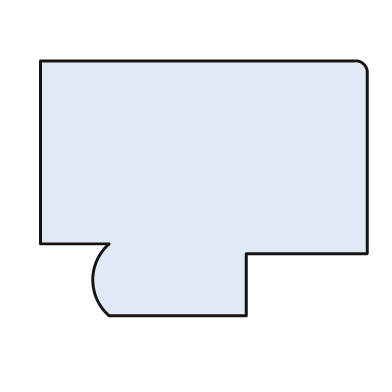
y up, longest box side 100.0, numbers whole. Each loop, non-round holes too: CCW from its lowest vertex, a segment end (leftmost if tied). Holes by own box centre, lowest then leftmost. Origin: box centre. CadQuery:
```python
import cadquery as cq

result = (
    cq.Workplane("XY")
    .moveTo(-29.0, -39.0)
    .lineTo(13.0, -39.0)
    .lineTo(13.0, -20.0)
    .lineTo(50.0, -20.0)
    .lineTo(50.0, 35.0)
    .threePointArc((49.0, 38.0), (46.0, 39.0))
    .lineTo(-50.0, 39.0)
    .lineTo(-50.0, -17.0)
    .lineTo(-29.0, -17.0)
    .threePointArc((-34.0, -28.0), (-29.0, -39.0))
    .close()
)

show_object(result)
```